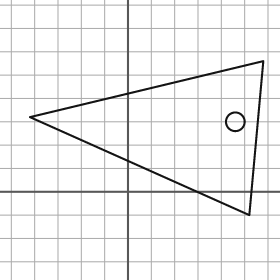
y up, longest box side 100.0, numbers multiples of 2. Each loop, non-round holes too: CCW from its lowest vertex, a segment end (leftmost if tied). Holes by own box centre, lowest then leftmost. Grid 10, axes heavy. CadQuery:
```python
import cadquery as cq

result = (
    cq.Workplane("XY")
    .moveTo(52.0, -10.0)
    .lineTo(58.0, 56.0)
    .lineTo(-42.0, 32.0)
    .close()
    .moveTo(46.0, 30.0)
    .circle(4.0)
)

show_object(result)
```